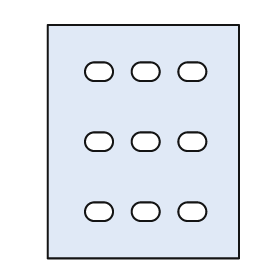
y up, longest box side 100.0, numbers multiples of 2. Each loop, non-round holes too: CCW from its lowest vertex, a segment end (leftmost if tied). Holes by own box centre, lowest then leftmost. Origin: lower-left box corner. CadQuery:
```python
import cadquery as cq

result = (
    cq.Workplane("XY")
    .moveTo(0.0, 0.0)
    .lineTo(82.0, 0.0)
    .lineTo(82.0, 100.0)
    .lineTo(0.0, 100.0)
    .close()
    .moveTo(20.0, 16.0)
    .lineTo(24.0, 16.0)
    .threePointArc((28.0, 20.0), (24.0, 24.0))
    .lineTo(20.0, 24.0)
    .threePointArc((16.0, 20.0), (20.0, 16.0))
    .close()
    .moveTo(40.0, 16.0)
    .lineTo(44.0, 16.0)
    .threePointArc((48.0, 20.0), (44.0, 24.0))
    .lineTo(40.0, 24.0)
    .threePointArc((36.0, 20.0), (40.0, 16.0))
    .close()
    .moveTo(60.0, 16.0)
    .lineTo(64.0, 16.0)
    .threePointArc((68.0, 20.0), (64.0, 24.0))
    .lineTo(60.0, 24.0)
    .threePointArc((56.0, 20.0), (60.0, 16.0))
    .close()
    .moveTo(20.0, 46.0)
    .lineTo(24.0, 46.0)
    .threePointArc((28.0, 50.0), (24.0, 54.0))
    .lineTo(20.0, 54.0)
    .threePointArc((16.0, 50.0), (20.0, 46.0))
    .close()
    .moveTo(40.0, 46.0)
    .lineTo(44.0, 46.0)
    .threePointArc((48.0, 50.0), (44.0, 54.0))
    .lineTo(40.0, 54.0)
    .threePointArc((36.0, 50.0), (40.0, 46.0))
    .close()
    .moveTo(60.0, 46.0)
    .lineTo(64.0, 46.0)
    .threePointArc((68.0, 50.0), (64.0, 54.0))
    .lineTo(60.0, 54.0)
    .threePointArc((56.0, 50.0), (60.0, 46.0))
    .close()
    .moveTo(20.0, 76.0)
    .lineTo(24.0, 76.0)
    .threePointArc((28.0, 80.0), (24.0, 84.0))
    .lineTo(20.0, 84.0)
    .threePointArc((16.0, 80.0), (20.0, 76.0))
    .close()
    .moveTo(40.0, 76.0)
    .lineTo(44.0, 76.0)
    .threePointArc((48.0, 80.0), (44.0, 84.0))
    .lineTo(40.0, 84.0)
    .threePointArc((36.0, 80.0), (40.0, 76.0))
    .close()
    .moveTo(60.0, 76.0)
    .lineTo(64.0, 76.0)
    .threePointArc((68.0, 80.0), (64.0, 84.0))
    .lineTo(60.0, 84.0)
    .threePointArc((56.0, 80.0), (60.0, 76.0))
    .close()
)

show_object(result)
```